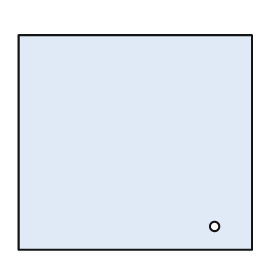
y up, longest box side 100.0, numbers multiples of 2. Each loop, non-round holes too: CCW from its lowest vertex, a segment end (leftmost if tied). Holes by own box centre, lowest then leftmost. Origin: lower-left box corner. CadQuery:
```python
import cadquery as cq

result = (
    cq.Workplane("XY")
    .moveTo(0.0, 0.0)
    .lineTo(100.0, 0.0)
    .lineTo(100.0, 92.0)
    .lineTo(0.0, 92.0)
    .close()
    .moveTo(84.0, 10.0)
    .circle(2.0)
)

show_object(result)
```